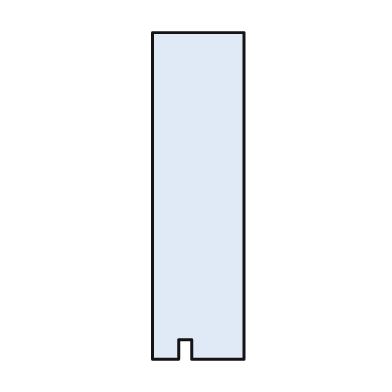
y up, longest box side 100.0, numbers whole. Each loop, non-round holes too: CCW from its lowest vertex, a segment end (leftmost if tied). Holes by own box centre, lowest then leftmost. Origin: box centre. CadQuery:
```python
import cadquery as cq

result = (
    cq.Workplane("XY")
    .moveTo(-14.0, -50.0)
    .lineTo(-6.0, -50.0)
    .lineTo(-6.0, -44.0)
    .lineTo(-2.0, -44.0)
    .lineTo(-2.0, -50.0)
    .lineTo(14.0, -50.0)
    .lineTo(14.0, 50.0)
    .lineTo(-14.0, 50.0)
    .close()
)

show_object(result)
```